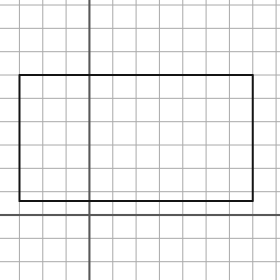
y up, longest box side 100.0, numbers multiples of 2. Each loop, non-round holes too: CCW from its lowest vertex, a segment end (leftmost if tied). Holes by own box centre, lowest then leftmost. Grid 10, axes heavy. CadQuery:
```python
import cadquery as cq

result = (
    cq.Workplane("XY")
    .moveTo(-30.0, 6.0)
    .lineTo(70.0, 6.0)
    .lineTo(70.0, 60.0)
    .lineTo(-30.0, 60.0)
    .close()
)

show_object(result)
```